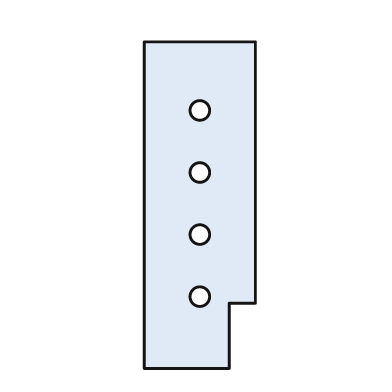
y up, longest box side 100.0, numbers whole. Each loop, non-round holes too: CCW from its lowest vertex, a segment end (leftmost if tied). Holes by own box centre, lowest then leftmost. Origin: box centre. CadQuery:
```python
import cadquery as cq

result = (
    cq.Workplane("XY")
    .moveTo(-17.0, -50.0)
    .lineTo(9.0, -50.0)
    .lineTo(9.0, -30.0)
    .lineTo(17.0, -30.0)
    .lineTo(17.0, 50.0)
    .lineTo(-17.0, 50.0)
    .close()
    .moveTo(0.0, -28.0)
    .circle(3.0)
    .moveTo(0.0, -9.0)
    .circle(3.0)
    .moveTo(0.0, 10.0)
    .circle(3.0)
    .moveTo(0.0, 29.0)
    .circle(3.0)
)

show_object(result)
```